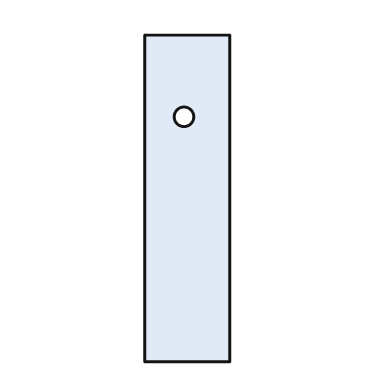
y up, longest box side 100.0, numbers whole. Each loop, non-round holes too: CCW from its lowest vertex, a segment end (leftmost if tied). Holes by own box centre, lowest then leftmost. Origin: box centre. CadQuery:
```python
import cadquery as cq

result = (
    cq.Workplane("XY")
    .moveTo(-13.0, -50.0)
    .lineTo(13.0, -50.0)
    .lineTo(13.0, 50.0)
    .lineTo(-13.0, 50.0)
    .close()
    .moveTo(-1.0, 25.0)
    .circle(3.0)
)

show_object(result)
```